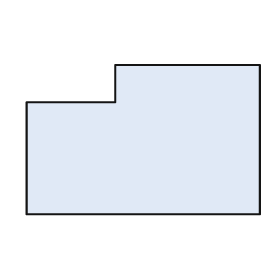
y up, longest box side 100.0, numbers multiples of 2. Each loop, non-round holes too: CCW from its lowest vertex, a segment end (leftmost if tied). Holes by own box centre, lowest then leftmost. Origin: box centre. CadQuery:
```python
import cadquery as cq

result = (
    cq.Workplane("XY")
    .moveTo(-50.0, -32.0)
    .lineTo(50.0, -32.0)
    .lineTo(50.0, 32.0)
    .lineTo(-12.0, 32.0)
    .lineTo(-12.0, 16.0)
    .lineTo(-50.0, 16.0)
    .close()
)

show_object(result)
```